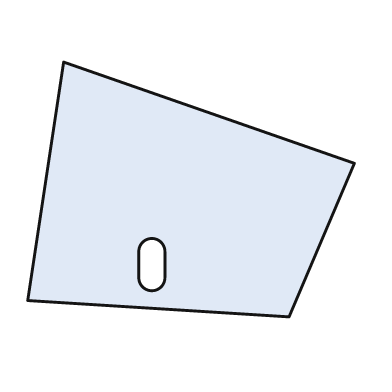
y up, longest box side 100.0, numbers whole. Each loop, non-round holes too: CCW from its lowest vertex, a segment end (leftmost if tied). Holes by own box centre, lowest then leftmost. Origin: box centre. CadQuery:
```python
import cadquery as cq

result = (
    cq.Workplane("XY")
    .moveTo(30.0, -39.0)
    .lineTo(50.0, 8.0)
    .lineTo(-39.0, 39.0)
    .lineTo(-50.0, -34.0)
    .close()
    .moveTo(-16.0, -27.0)
    .threePointArc((-12.0, -31.0), (-8.0, -27.0))
    .lineTo(-8.0, -19.0)
    .threePointArc((-12.0, -15.0), (-16.0, -19.0))
    .close()
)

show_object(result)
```